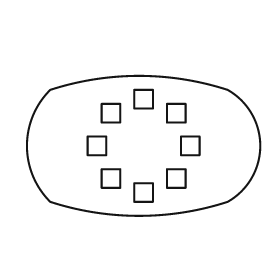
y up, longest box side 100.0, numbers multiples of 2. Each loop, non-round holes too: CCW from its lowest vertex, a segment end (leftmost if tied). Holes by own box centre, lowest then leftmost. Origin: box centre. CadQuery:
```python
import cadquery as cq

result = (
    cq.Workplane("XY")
    .moveTo(-40.0, -24.0)
    .threePointArc((-2.0, -30.0), (36.0, -24.0))
    .threePointArc((50.0, 0.0), (36.0, 24.0))
    .threePointArc((-2.0, 30.0), (-40.0, 24.0))
    .threePointArc((-50.0, 0.0), (-40.0, -24.0))
    .close()
    .moveTo(-4.0, -24.0)
    .lineTo(4.0, -24.0)
    .lineTo(4.0, -16.0)
    .lineTo(-4.0, -16.0)
    .close()
    .moveTo(-18.0, -18.0)
    .lineTo(-10.0, -18.0)
    .lineTo(-10.0, -10.0)
    .lineTo(-18.0, -10.0)
    .close()
    .moveTo(10.0, -18.0)
    .lineTo(18.0, -18.0)
    .lineTo(18.0, -10.0)
    .lineTo(10.0, -10.0)
    .close()
    .moveTo(-24.0, -4.0)
    .lineTo(-16.0, -4.0)
    .lineTo(-16.0, 4.0)
    .lineTo(-24.0, 4.0)
    .close()
    .moveTo(16.0, -4.0)
    .lineTo(24.0, -4.0)
    .lineTo(24.0, 4.0)
    .lineTo(16.0, 4.0)
    .close()
    .moveTo(-18.0, 10.0)
    .lineTo(-10.0, 10.0)
    .lineTo(-10.0, 18.0)
    .lineTo(-18.0, 18.0)
    .close()
    .moveTo(10.0, 10.0)
    .lineTo(18.0, 10.0)
    .lineTo(18.0, 18.0)
    .lineTo(10.0, 18.0)
    .close()
    .moveTo(-4.0, 16.0)
    .lineTo(4.0, 16.0)
    .lineTo(4.0, 24.0)
    .lineTo(-4.0, 24.0)
    .close()
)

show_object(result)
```